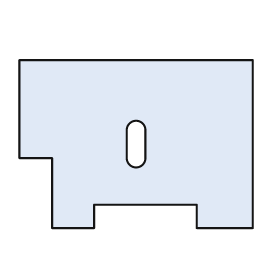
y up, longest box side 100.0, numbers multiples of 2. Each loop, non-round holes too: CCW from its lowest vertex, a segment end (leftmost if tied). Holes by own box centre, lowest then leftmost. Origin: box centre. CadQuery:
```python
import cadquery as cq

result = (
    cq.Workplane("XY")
    .moveTo(-36.0, -36.0)
    .lineTo(-18.0, -36.0)
    .lineTo(-18.0, -26.0)
    .lineTo(26.0, -26.0)
    .lineTo(26.0, -36.0)
    .lineTo(50.0, -36.0)
    .lineTo(50.0, 36.0)
    .lineTo(-50.0, 36.0)
    .lineTo(-50.0, -6.0)
    .lineTo(-36.0, -6.0)
    .close()
    .moveTo(-4.0, -6.0)
    .threePointArc((0.0, -10.0), (4.0, -6.0))
    .lineTo(4.0, 6.0)
    .threePointArc((0.0, 10.0), (-4.0, 6.0))
    .close()
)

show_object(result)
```